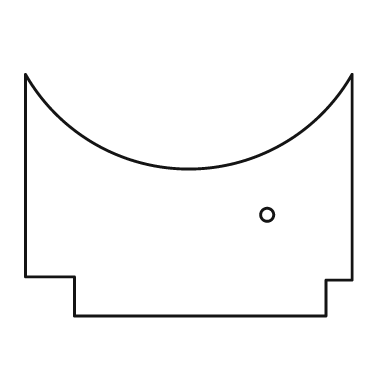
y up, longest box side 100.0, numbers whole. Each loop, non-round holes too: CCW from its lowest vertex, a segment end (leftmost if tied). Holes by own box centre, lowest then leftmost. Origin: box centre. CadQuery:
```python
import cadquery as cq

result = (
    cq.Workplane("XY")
    .moveTo(-35.0, -37.0)
    .lineTo(42.0, -37.0)
    .lineTo(42.0, -26.0)
    .lineTo(50.0, -26.0)
    .lineTo(50.0, 37.0)
    .threePointArc((0.0, 8.0), (-50.0, 37.0))
    .lineTo(-50.0, -25.0)
    .lineTo(-35.0, -25.0)
    .close()
    .moveTo(24.0, -6.0)
    .circle(2.0)
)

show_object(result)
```